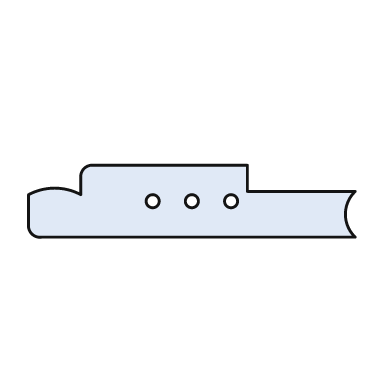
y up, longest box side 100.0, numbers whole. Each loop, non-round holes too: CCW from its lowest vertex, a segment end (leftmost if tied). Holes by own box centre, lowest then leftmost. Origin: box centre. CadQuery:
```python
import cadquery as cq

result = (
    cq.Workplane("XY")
    .moveTo(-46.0, -11.0)
    .lineTo(50.0, -11.0)
    .threePointArc((47.0, -4.0), (50.0, 3.0))
    .lineTo(17.0, 3.0)
    .lineTo(17.0, 11.0)
    .lineTo(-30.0, 11.0)
    .threePointArc((-33.0, 10.0), (-34.0, 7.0))
    .lineTo(-34.0, 2.0)
    .threePointArc((-42.0, 4.0), (-50.0, 2.0))
    .lineTo(-50.0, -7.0)
    .threePointArc((-49.0, -10.0), (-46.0, -11.0))
    .close()
    .moveTo(-12.0, 0.0)
    .circle(2.0)
    .moveTo(0.0, 0.0)
    .circle(2.0)
    .moveTo(12.0, 0.0)
    .circle(2.0)
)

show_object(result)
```